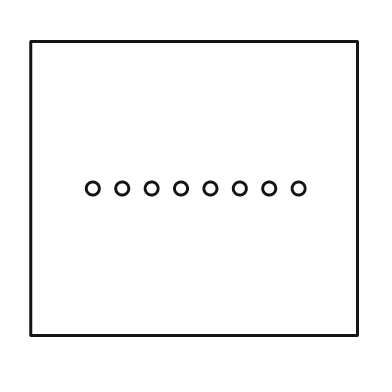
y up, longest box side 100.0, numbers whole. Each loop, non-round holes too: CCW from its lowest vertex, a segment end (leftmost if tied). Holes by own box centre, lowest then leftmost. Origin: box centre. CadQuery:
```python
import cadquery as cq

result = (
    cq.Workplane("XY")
    .moveTo(-50.0, -45.0)
    .lineTo(50.0, -45.0)
    .lineTo(50.0, 45.0)
    .lineTo(-50.0, 45.0)
    .close()
    .moveTo(-31.0, 0.0)
    .circle(2.0)
    .moveTo(-22.0, 0.0)
    .circle(2.0)
    .moveTo(-13.0, 0.0)
    .circle(2.0)
    .moveTo(-4.0, 0.0)
    .circle(2.0)
    .moveTo(5.0, 0.0)
    .circle(2.0)
    .moveTo(14.0, 0.0)
    .circle(2.0)
    .moveTo(23.0, 0.0)
    .circle(2.0)
    .moveTo(32.0, 0.0)
    .circle(2.0)
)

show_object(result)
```